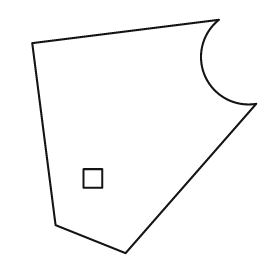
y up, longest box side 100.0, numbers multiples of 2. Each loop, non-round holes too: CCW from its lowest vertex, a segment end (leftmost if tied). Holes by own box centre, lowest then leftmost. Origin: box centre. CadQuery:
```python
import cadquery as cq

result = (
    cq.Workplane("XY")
    .moveTo(-8.0, -50.0)
    .lineTo(48.0, 14.0)
    .threePointArc((26.0, 26.0), (32.0, 50.0))
    .lineTo(-48.0, 40.0)
    .lineTo(-38.0, -38.0)
    .close()
    .moveTo(-26.0, -22.0)
    .lineTo(-18.0, -22.0)
    .lineTo(-18.0, -14.0)
    .lineTo(-26.0, -14.0)
    .close()
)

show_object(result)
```